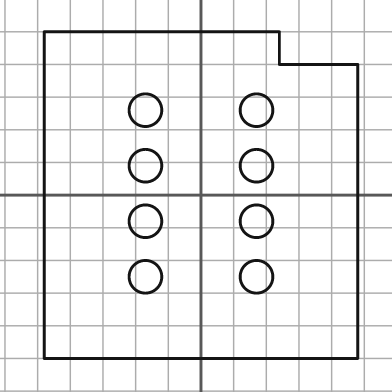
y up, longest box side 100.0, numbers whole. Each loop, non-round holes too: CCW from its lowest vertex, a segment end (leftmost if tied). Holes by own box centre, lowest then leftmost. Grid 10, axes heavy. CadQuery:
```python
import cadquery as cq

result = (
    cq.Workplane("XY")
    .moveTo(-48.0, -50.0)
    .lineTo(48.0, -50.0)
    .lineTo(48.0, 40.0)
    .lineTo(24.0, 40.0)
    .lineTo(24.0, 50.0)
    .lineTo(-48.0, 50.0)
    .close()
    .moveTo(-17.0, -25.0)
    .circle(5.0)
    .moveTo(17.0, -25.0)
    .circle(5.0)
    .moveTo(-17.0, -8.0)
    .circle(5.0)
    .moveTo(17.0, -8.0)
    .circle(5.0)
    .moveTo(-17.0, 9.0)
    .circle(5.0)
    .moveTo(17.0, 9.0)
    .circle(5.0)
    .moveTo(-17.0, 26.0)
    .circle(5.0)
    .moveTo(17.0, 26.0)
    .circle(5.0)
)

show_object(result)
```